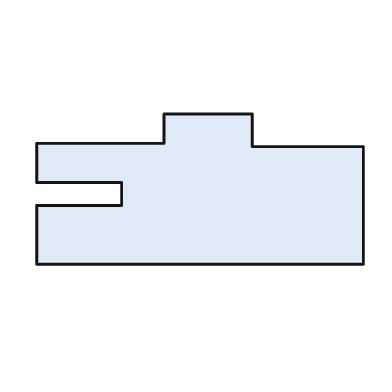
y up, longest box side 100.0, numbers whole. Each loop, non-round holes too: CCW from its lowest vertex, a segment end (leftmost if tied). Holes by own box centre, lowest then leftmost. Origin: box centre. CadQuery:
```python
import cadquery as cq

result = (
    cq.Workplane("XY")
    .moveTo(-50.0, -23.0)
    .lineTo(50.0, -23.0)
    .lineTo(50.0, 13.0)
    .lineTo(16.0, 13.0)
    .lineTo(16.0, 23.0)
    .lineTo(-11.0, 23.0)
    .lineTo(-11.0, 14.0)
    .lineTo(-50.0, 14.0)
    .lineTo(-50.0, 2.0)
    .lineTo(-24.0, 2.0)
    .lineTo(-24.0, -5.0)
    .lineTo(-50.0, -5.0)
    .close()
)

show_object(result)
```